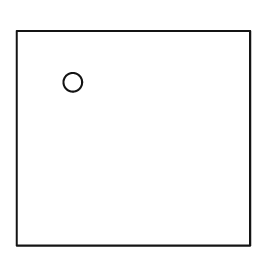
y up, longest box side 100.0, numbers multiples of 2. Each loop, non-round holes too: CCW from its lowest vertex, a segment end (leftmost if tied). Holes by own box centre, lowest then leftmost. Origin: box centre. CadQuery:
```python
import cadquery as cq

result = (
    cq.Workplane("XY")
    .moveTo(-50.0, -46.0)
    .lineTo(50.0, -46.0)
    .lineTo(50.0, 46.0)
    .lineTo(-50.0, 46.0)
    .close()
    .moveTo(-26.0, 24.0)
    .circle(4.0)
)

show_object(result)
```